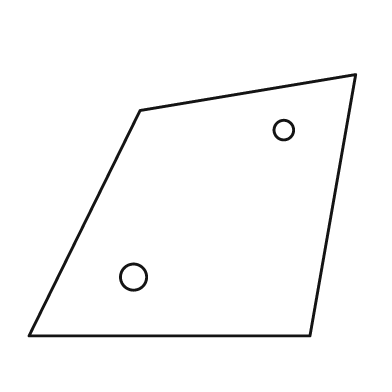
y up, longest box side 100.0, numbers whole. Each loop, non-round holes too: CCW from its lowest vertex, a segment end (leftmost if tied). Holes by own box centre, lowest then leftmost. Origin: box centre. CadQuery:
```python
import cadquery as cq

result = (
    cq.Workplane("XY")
    .moveTo(-50.0, -40.0)
    .lineTo(36.0, -40.0)
    .lineTo(50.0, 40.0)
    .lineTo(-16.0, 29.0)
    .close()
    .moveTo(-18.0, -22.0)
    .circle(4.0)
    .moveTo(28.0, 23.0)
    .circle(3.0)
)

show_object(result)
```